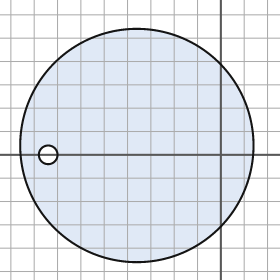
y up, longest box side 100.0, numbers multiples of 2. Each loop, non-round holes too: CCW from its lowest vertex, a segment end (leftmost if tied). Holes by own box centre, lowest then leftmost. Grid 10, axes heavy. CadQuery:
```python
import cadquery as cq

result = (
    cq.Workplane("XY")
    .moveTo(-36.0, 4.0)
    .circle(50.0)
    .moveTo(-74.0, 0.0)
    .circle(4.0)
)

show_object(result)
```